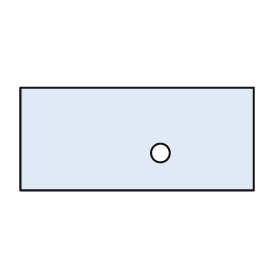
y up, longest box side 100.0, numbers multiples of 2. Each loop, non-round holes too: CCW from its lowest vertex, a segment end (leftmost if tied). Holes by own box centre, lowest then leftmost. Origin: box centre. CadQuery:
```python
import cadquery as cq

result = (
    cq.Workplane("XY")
    .moveTo(-50.0, -22.0)
    .lineTo(50.0, -22.0)
    .lineTo(50.0, 22.0)
    .lineTo(-50.0, 22.0)
    .close()
    .moveTo(10.0, -6.0)
    .circle(4.0)
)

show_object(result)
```